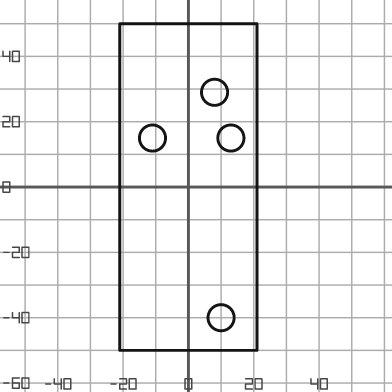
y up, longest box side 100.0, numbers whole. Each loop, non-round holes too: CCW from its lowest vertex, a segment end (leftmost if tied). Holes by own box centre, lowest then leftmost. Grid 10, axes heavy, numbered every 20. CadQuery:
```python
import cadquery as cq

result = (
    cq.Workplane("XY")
    .moveTo(-21.0, -50.0)
    .lineTo(21.0, -50.0)
    .lineTo(21.0, 50.0)
    .lineTo(-21.0, 50.0)
    .close()
    .moveTo(10.0, -40.0)
    .circle(4.0)
    .moveTo(-11.0, 15.0)
    .circle(4.0)
    .moveTo(13.0, 15.0)
    .circle(4.0)
    .moveTo(8.0, 29.0)
    .circle(4.0)
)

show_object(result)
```